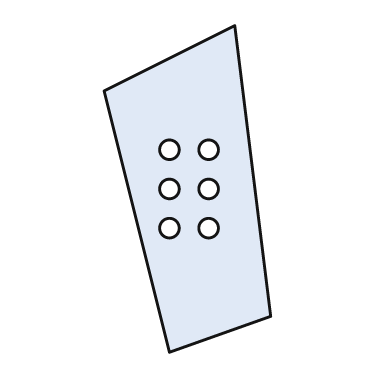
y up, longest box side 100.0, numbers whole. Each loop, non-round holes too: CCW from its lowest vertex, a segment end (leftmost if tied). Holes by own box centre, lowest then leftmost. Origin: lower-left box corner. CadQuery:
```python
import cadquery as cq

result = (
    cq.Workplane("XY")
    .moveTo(20.0, 0.0)
    .lineTo(51.0, 11.0)
    .lineTo(40.0, 100.0)
    .lineTo(0.0, 80.0)
    .close()
    .moveTo(20.0, 38.0)
    .circle(3.0)
    .moveTo(32.0, 38.0)
    .circle(3.0)
    .moveTo(20.0, 50.0)
    .circle(3.0)
    .moveTo(32.0, 50.0)
    .circle(3.0)
    .moveTo(20.0, 62.0)
    .circle(3.0)
    .moveTo(32.0, 62.0)
    .circle(3.0)
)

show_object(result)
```